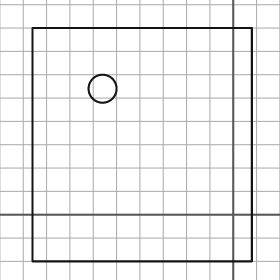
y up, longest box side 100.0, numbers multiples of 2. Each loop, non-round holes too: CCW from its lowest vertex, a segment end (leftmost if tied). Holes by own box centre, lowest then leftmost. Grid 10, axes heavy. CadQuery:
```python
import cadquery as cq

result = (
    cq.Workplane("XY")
    .moveTo(-86.0, -20.0)
    .lineTo(8.0, -20.0)
    .lineTo(8.0, 80.0)
    .lineTo(-86.0, 80.0)
    .close()
    .moveTo(-56.0, 54.0)
    .circle(6.0)
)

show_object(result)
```